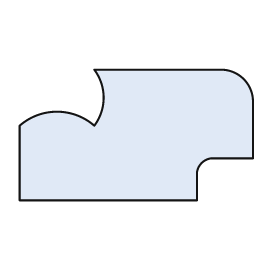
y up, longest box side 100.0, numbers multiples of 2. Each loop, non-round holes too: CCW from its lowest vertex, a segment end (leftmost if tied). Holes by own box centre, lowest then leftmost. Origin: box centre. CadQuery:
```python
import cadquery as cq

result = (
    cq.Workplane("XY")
    .moveTo(-50.0, -28.0)
    .lineTo(26.0, -28.0)
    .lineTo(26.0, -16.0)
    .threePointArc((28.0, -12.0), (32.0, -10.0))
    .lineTo(50.0, -10.0)
    .lineTo(50.0, 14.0)
    .threePointArc((46.0, 24.0), (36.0, 28.0))
    .lineTo(-18.0, 28.0)
    .threePointArc((-14.0, 16.0), (-18.0, 4.0))
    .threePointArc((-34.0, 10.0), (-50.0, 4.0))
    .close()
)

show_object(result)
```